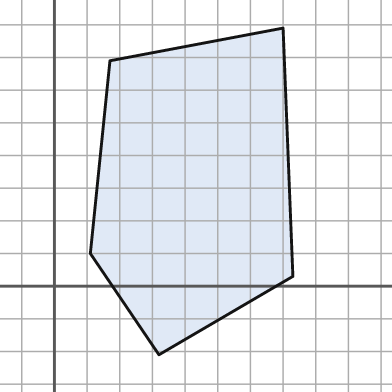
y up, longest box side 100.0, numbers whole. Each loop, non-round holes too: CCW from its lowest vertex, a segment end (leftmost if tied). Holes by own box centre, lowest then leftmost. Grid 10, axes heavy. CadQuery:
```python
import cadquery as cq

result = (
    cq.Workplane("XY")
    .moveTo(32.0, -21.0)
    .lineTo(73.0, 3.0)
    .lineTo(70.0, 79.0)
    .lineTo(17.0, 69.0)
    .lineTo(11.0, 10.0)
    .close()
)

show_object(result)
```